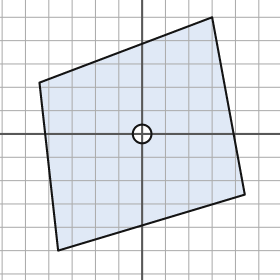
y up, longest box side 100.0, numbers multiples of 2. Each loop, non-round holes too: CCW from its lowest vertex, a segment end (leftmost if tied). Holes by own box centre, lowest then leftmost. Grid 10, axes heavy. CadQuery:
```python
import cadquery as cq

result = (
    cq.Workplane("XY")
    .moveTo(-36.0, -50.0)
    .lineTo(44.0, -26.0)
    .lineTo(30.0, 50.0)
    .lineTo(-44.0, 22.0)
    .close()
    .moveTo(0.0, 0.0)
    .circle(4.0)
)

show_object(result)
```